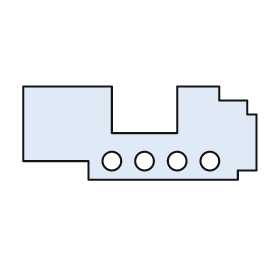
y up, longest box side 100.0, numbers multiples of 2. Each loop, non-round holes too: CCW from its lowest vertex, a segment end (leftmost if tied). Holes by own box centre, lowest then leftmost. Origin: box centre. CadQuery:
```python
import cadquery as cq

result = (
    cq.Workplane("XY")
    .moveTo(-22.0, -20.0)
    .lineTo(42.0, -20.0)
    .lineTo(42.0, -16.0)
    .lineTo(50.0, -16.0)
    .lineTo(50.0, 8.0)
    .lineTo(46.0, 8.0)
    .lineTo(46.0, 14.0)
    .lineTo(34.0, 14.0)
    .lineTo(34.0, 20.0)
    .lineTo(16.0, 20.0)
    .lineTo(16.0, 0.0)
    .lineTo(-12.0, 0.0)
    .lineTo(-12.0, 20.0)
    .lineTo(-50.0, 20.0)
    .lineTo(-50.0, -12.0)
    .lineTo(-22.0, -12.0)
    .close()
    .moveTo(-12.0, -12.0)
    .circle(4.0)
    .moveTo(2.0, -12.0)
    .circle(4.0)
    .moveTo(16.0, -12.0)
    .circle(4.0)
    .moveTo(30.0, -12.0)
    .circle(4.0)
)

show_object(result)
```